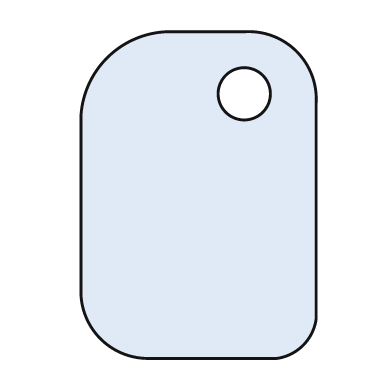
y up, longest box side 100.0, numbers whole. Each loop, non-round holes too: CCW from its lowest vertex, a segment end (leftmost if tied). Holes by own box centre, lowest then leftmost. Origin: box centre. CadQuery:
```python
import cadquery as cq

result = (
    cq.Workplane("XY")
    .moveTo(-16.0, -50.0)
    .lineTo(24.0, -50.0)
    .threePointArc((32.0, -46.0), (36.0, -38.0))
    .lineTo(36.0, 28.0)
    .threePointArc((30.0, 44.0), (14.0, 50.0))
    .lineTo(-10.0, 50.0)
    .threePointArc((-28.0, 42.0), (-36.0, 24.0))
    .lineTo(-36.0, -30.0)
    .threePointArc((-30.0, -44.0), (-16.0, -50.0))
    .close()
    .moveTo(14.0, 31.0)
    .circle(8.0)
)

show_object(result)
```